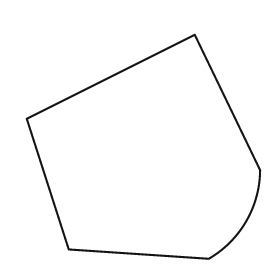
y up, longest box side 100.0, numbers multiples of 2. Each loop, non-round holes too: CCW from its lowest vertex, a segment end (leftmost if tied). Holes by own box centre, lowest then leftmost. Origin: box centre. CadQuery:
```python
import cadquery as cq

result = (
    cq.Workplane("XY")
    .moveTo(28.0, -48.0)
    .threePointArc((44.0, -32.0), (50.0, -10.0))
    .lineTo(22.0, 48.0)
    .lineTo(-50.0, 12.0)
    .lineTo(-32.0, -44.0)
    .close()
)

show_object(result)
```